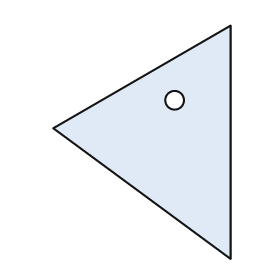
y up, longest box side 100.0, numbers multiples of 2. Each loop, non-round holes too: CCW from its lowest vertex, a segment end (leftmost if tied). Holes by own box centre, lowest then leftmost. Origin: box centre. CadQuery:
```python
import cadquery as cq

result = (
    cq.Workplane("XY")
    .moveTo(38.0, -50.0)
    .lineTo(38.0, 50.0)
    .lineTo(-38.0, 6.0)
    .close()
    .moveTo(14.0, 18.0)
    .circle(4.0)
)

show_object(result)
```